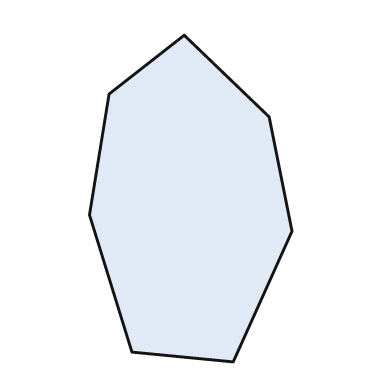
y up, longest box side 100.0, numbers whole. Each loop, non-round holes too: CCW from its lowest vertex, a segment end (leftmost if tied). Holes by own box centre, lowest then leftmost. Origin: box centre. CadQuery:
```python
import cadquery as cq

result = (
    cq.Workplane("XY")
    .moveTo(13.0, -50.0)
    .lineTo(31.0, -10.0)
    .lineTo(24.0, 25.0)
    .lineTo(-2.0, 50.0)
    .lineTo(-25.0, 32.0)
    .lineTo(-31.0, -5.0)
    .lineTo(-18.0, -47.0)
    .close()
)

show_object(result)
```